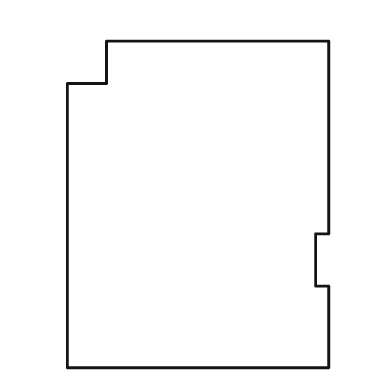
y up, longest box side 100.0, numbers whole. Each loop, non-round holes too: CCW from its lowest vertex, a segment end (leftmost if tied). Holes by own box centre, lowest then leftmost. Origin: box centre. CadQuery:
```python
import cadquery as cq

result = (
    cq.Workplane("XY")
    .moveTo(-40.0, -50.0)
    .lineTo(40.0, -50.0)
    .lineTo(40.0, -25.0)
    .lineTo(36.0, -25.0)
    .lineTo(36.0, -9.0)
    .lineTo(40.0, -9.0)
    .lineTo(40.0, 50.0)
    .lineTo(-28.0, 50.0)
    .lineTo(-28.0, 37.0)
    .lineTo(-40.0, 37.0)
    .close()
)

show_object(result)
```